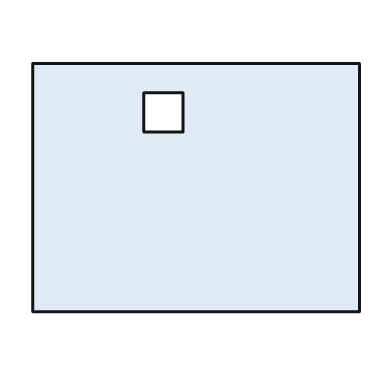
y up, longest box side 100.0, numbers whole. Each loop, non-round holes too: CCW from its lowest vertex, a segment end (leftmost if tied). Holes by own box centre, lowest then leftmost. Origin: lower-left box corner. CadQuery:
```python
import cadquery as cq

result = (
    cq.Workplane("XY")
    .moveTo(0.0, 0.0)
    .lineTo(100.0, 0.0)
    .lineTo(100.0, 76.0)
    .lineTo(0.0, 76.0)
    .close()
    .moveTo(34.0, 55.0)
    .lineTo(46.0, 55.0)
    .lineTo(46.0, 67.0)
    .lineTo(34.0, 67.0)
    .close()
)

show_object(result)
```